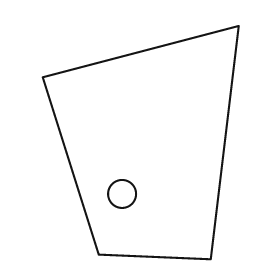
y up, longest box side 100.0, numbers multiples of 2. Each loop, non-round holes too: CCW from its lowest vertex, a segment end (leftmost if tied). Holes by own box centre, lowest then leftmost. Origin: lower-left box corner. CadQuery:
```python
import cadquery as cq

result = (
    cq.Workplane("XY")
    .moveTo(72.0, 0.0)
    .lineTo(84.0, 100.0)
    .lineTo(0.0, 78.0)
    .lineTo(24.0, 2.0)
    .close()
    .moveTo(34.0, 28.0)
    .circle(6.0)
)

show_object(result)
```